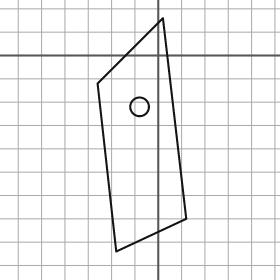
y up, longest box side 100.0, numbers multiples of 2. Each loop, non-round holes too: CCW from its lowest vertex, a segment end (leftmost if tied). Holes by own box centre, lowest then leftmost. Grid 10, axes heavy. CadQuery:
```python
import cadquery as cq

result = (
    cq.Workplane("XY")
    .moveTo(-18.0, -84.0)
    .lineTo(12.0, -70.0)
    .lineTo(2.0, 16.0)
    .lineTo(-26.0, -12.0)
    .close()
    .moveTo(-8.0, -22.0)
    .circle(4.0)
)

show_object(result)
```